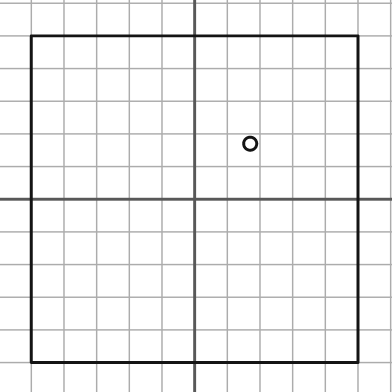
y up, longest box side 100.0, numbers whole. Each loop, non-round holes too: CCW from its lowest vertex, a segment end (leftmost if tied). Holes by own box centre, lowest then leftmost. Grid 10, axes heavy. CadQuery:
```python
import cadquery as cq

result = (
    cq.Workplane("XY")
    .moveTo(-50.0, -50.0)
    .lineTo(50.0, -50.0)
    .lineTo(50.0, 50.0)
    .lineTo(-50.0, 50.0)
    .close()
    .moveTo(17.0, 17.0)
    .circle(2.0)
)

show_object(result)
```